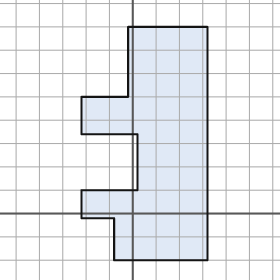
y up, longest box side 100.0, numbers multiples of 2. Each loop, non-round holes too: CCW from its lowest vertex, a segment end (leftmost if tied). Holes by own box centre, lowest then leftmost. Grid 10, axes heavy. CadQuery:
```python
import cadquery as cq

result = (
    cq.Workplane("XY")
    .moveTo(-8.0, -20.0)
    .lineTo(32.0, -20.0)
    .lineTo(32.0, 80.0)
    .lineTo(-2.0, 80.0)
    .lineTo(-2.0, 50.0)
    .lineTo(-22.0, 50.0)
    .lineTo(-22.0, 34.0)
    .lineTo(2.0, 34.0)
    .lineTo(2.0, 10.0)
    .lineTo(-22.0, 10.0)
    .lineTo(-22.0, -2.0)
    .lineTo(-8.0, -2.0)
    .close()
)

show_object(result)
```